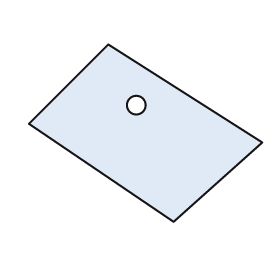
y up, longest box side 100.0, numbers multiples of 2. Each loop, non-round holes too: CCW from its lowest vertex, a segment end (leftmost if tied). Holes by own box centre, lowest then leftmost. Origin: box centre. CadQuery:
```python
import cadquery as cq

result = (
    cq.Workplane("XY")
    .moveTo(12.0, -38.0)
    .lineTo(50.0, -4.0)
    .lineTo(-16.0, 38.0)
    .lineTo(-50.0, 4.0)
    .close()
    .moveTo(-4.0, 12.0)
    .circle(4.0)
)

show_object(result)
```